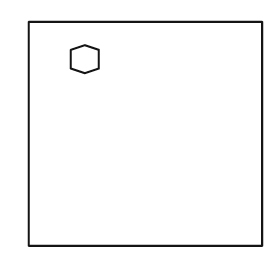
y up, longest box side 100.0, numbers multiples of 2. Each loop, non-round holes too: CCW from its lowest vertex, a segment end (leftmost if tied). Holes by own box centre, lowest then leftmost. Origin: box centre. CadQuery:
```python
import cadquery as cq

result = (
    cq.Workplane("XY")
    .moveTo(-50.0, -48.0)
    .lineTo(50.0, -48.0)
    .lineTo(50.0, 48.0)
    .lineTo(-50.0, 48.0)
    .close()
    .moveTo(-26.0, 26.0)
    .lineTo(-20.0, 28.0)
    .lineTo(-20.0, 36.0)
    .lineTo(-26.0, 38.0)
    .lineTo(-32.0, 36.0)
    .lineTo(-32.0, 28.0)
    .close()
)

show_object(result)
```